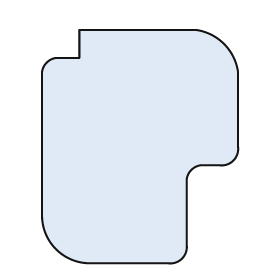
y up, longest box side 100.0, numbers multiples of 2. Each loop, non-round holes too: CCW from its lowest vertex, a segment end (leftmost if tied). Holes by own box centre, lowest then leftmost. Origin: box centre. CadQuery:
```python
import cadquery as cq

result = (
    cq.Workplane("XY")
    .moveTo(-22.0, -50.0)
    .lineTo(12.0, -50.0)
    .threePointArc((18.0, -48.0), (20.0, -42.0))
    .lineTo(20.0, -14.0)
    .threePointArc((22.0, -10.0), (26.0, -8.0))
    .lineTo(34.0, -8.0)
    .threePointArc((40.0, -6.0), (42.0, 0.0))
    .lineTo(42.0, 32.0)
    .threePointArc((36.0, 44.0), (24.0, 50.0))
    .lineTo(-26.0, 50.0)
    .lineTo(-26.0, 38.0)
    .lineTo(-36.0, 38.0)
    .threePointArc((-40.0, 36.0), (-42.0, 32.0))
    .lineTo(-42.0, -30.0)
    .threePointArc((-36.0, -44.0), (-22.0, -50.0))
    .close()
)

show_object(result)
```